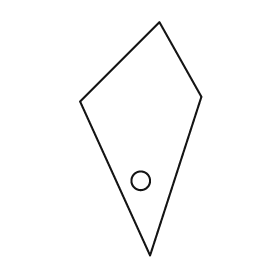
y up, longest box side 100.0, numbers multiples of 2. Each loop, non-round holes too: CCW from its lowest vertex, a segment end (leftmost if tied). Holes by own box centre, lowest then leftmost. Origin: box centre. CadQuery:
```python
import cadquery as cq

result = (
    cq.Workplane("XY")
    .moveTo(4.0, -50.0)
    .lineTo(26.0, 18.0)
    .lineTo(8.0, 50.0)
    .lineTo(-26.0, 16.0)
    .close()
    .moveTo(0.0, -18.0)
    .circle(4.0)
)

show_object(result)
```